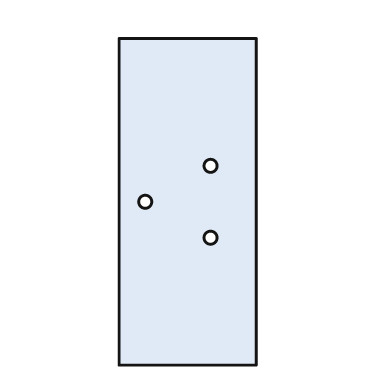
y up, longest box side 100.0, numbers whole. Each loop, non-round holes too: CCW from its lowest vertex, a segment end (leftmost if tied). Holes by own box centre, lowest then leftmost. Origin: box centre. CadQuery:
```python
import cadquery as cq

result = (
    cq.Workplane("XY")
    .moveTo(-21.0, -50.0)
    .lineTo(21.0, -50.0)
    .lineTo(21.0, 50.0)
    .lineTo(-21.0, 50.0)
    .close()
    .moveTo(7.0, -11.0)
    .circle(2.0)
    .moveTo(-13.0, 0.0)
    .circle(2.0)
    .moveTo(7.0, 11.0)
    .circle(2.0)
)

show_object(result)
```